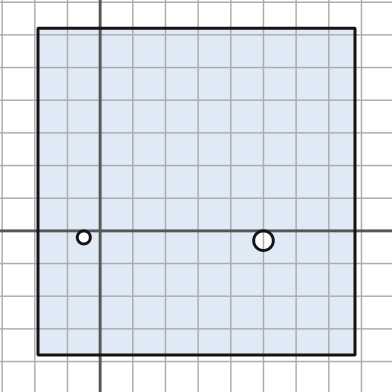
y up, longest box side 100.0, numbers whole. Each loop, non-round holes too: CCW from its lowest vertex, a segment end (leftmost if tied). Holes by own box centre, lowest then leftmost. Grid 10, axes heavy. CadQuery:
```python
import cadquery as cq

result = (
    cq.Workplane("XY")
    .moveTo(-19.0, -38.0)
    .lineTo(78.0, -38.0)
    .lineTo(78.0, 62.0)
    .lineTo(-19.0, 62.0)
    .close()
    .moveTo(50.0, -3.0)
    .circle(3.0)
    .moveTo(-5.0, -2.0)
    .circle(2.0)
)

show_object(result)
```